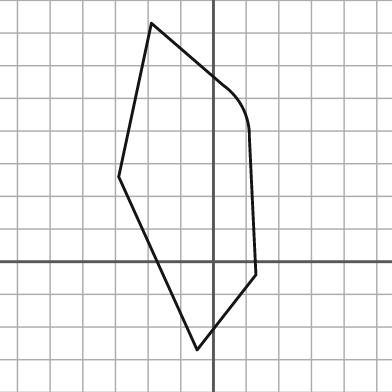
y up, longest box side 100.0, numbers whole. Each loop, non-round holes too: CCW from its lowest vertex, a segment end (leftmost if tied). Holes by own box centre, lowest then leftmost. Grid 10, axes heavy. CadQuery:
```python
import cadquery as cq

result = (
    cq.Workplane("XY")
    .moveTo(-5.0, -27.0)
    .lineTo(13.0, -4.0)
    .lineTo(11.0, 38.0)
    .threePointArc((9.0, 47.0), (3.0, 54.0))
    .lineTo(-19.0, 73.0)
    .lineTo(-29.0, 26.0)
    .close()
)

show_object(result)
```